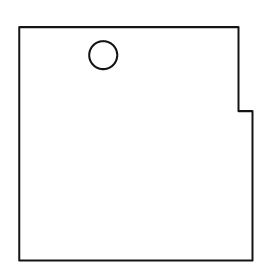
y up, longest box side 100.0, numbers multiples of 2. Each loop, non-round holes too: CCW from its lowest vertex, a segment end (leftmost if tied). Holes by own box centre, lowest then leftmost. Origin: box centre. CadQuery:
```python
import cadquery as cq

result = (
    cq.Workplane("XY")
    .moveTo(-50.0, -50.0)
    .lineTo(50.0, -50.0)
    .lineTo(50.0, 14.0)
    .lineTo(44.0, 14.0)
    .lineTo(44.0, 50.0)
    .lineTo(-50.0, 50.0)
    .close()
    .moveTo(-14.0, 38.0)
    .circle(6.0)
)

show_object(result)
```